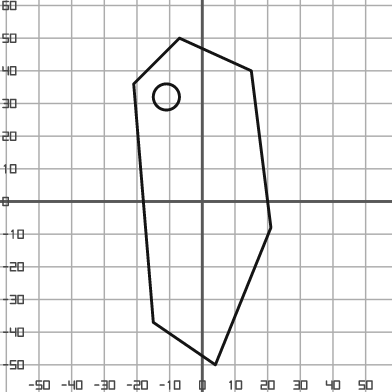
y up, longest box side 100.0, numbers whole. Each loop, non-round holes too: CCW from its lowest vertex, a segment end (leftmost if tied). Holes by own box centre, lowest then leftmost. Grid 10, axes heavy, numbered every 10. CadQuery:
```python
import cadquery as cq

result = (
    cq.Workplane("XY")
    .moveTo(4.0, -50.0)
    .lineTo(21.0, -8.0)
    .lineTo(15.0, 40.0)
    .lineTo(-7.0, 50.0)
    .lineTo(-21.0, 36.0)
    .lineTo(-15.0, -37.0)
    .close()
    .moveTo(-11.0, 32.0)
    .circle(4.0)
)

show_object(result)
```